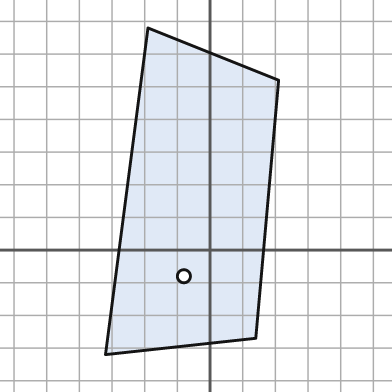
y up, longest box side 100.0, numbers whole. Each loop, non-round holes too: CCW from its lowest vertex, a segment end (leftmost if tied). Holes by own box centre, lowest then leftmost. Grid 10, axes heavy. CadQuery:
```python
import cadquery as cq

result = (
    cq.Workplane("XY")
    .moveTo(-32.0, -32.0)
    .lineTo(14.0, -27.0)
    .lineTo(21.0, 52.0)
    .lineTo(-19.0, 68.0)
    .close()
    .moveTo(-8.0, -8.0)
    .circle(2.0)
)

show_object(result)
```